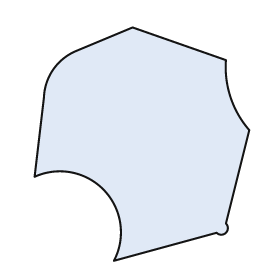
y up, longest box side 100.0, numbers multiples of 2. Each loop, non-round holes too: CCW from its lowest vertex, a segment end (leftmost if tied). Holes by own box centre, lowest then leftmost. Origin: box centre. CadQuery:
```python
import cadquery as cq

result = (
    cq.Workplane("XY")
    .moveTo(-12.0, -50.0)
    .lineTo(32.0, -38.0)
    .threePointArc((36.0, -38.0), (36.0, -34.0))
    .lineTo(46.0, 6.0)
    .threePointArc((38.0, 20.0), (36.0, 36.0))
    .lineTo(-4.0, 50.0)
    .lineTo(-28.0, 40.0)
    .threePointArc((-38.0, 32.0), (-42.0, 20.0))
    .lineTo(-46.0, -14.0)
    .threePointArc((-16.0, -20.0), (-12.0, -50.0))
    .close()
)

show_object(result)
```